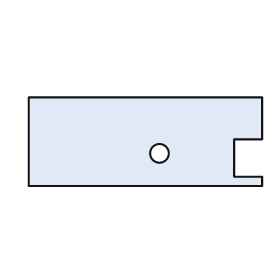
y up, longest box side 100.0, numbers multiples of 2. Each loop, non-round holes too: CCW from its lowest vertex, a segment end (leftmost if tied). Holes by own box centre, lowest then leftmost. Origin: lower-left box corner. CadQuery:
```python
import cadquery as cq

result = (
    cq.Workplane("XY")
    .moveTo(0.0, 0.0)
    .lineTo(100.0, 0.0)
    .lineTo(100.0, 4.0)
    .lineTo(88.0, 4.0)
    .lineTo(88.0, 20.0)
    .lineTo(100.0, 20.0)
    .lineTo(100.0, 38.0)
    .lineTo(0.0, 38.0)
    .close()
    .moveTo(56.0, 14.0)
    .circle(4.0)
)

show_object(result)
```